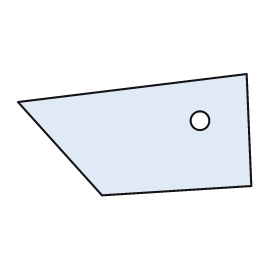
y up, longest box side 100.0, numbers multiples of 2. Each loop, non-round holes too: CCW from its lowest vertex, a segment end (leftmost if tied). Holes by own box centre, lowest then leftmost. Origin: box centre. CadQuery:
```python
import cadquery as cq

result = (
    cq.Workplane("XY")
    .moveTo(-14.0, -26.0)
    .lineTo(50.0, -22.0)
    .lineTo(48.0, 26.0)
    .lineTo(-50.0, 14.0)
    .close()
    .moveTo(28.0, 6.0)
    .circle(4.0)
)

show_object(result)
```